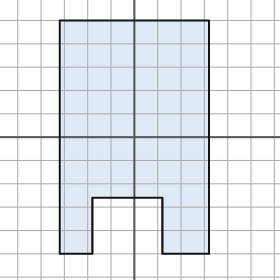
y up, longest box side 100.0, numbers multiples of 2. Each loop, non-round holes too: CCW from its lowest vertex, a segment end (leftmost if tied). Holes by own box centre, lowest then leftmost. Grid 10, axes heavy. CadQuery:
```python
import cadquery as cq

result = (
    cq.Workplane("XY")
    .moveTo(-32.0, -50.0)
    .lineTo(-18.0, -50.0)
    .lineTo(-18.0, -26.0)
    .lineTo(12.0, -26.0)
    .lineTo(12.0, -50.0)
    .lineTo(32.0, -50.0)
    .lineTo(32.0, 50.0)
    .lineTo(-32.0, 50.0)
    .close()
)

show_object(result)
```